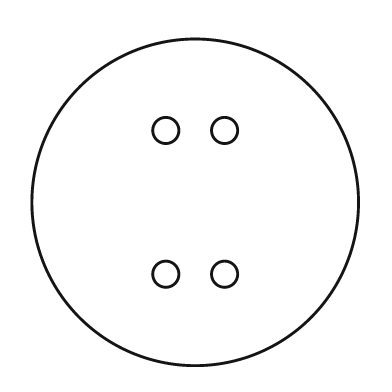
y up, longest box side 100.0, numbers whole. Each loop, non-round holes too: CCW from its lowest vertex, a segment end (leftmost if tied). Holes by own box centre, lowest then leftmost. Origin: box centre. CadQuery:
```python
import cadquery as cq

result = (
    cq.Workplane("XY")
    .moveTo(0.0, 0.0)
    .circle(50.0)
    .moveTo(-9.0, -22.0)
    .circle(4.0)
    .moveTo(9.0, -22.0)
    .circle(4.0)
    .moveTo(-9.0, 22.0)
    .circle(4.0)
    .moveTo(9.0, 22.0)
    .circle(4.0)
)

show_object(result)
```